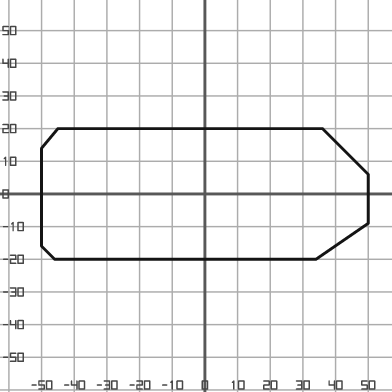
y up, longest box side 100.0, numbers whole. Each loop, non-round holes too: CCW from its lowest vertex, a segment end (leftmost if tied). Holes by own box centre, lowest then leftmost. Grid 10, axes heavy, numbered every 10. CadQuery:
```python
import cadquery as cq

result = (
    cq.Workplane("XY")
    .moveTo(-46.0, -20.0)
    .lineTo(34.0, -20.0)
    .lineTo(50.0, -9.0)
    .lineTo(50.0, 6.0)
    .lineTo(36.0, 20.0)
    .lineTo(-45.0, 20.0)
    .lineTo(-50.0, 14.0)
    .lineTo(-50.0, -16.0)
    .close()
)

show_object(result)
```